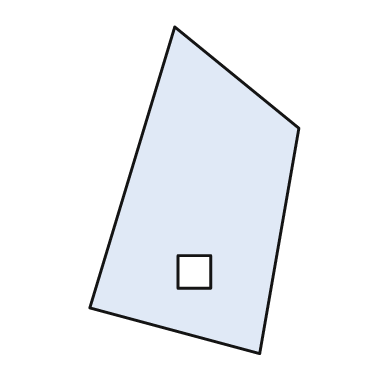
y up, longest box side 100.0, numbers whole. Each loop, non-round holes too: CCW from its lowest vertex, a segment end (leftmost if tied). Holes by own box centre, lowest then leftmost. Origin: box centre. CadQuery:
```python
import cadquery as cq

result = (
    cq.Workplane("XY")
    .moveTo(20.0, -50.0)
    .lineTo(32.0, 19.0)
    .lineTo(-6.0, 50.0)
    .lineTo(-32.0, -36.0)
    .close()
    .moveTo(-5.0, -30.0)
    .lineTo(5.0, -30.0)
    .lineTo(5.0, -20.0)
    .lineTo(-5.0, -20.0)
    .close()
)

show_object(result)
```